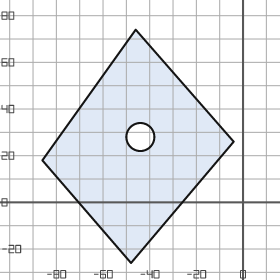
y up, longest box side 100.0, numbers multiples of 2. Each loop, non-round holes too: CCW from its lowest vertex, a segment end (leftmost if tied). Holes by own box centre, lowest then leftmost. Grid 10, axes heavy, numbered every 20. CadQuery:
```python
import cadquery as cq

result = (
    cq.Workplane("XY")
    .moveTo(-48.0, -26.0)
    .lineTo(-4.0, 26.0)
    .lineTo(-46.0, 74.0)
    .lineTo(-86.0, 18.0)
    .close()
    .moveTo(-44.0, 28.0)
    .circle(6.0)
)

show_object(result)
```